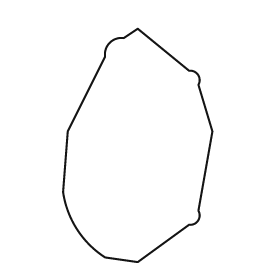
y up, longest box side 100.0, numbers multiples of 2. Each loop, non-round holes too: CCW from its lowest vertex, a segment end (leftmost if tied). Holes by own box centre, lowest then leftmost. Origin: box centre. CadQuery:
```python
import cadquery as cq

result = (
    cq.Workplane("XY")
    .moveTo(0.0, -50.0)
    .lineTo(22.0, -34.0)
    .threePointArc((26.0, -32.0), (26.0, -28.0))
    .lineTo(32.0, 6.0)
    .lineTo(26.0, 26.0)
    .threePointArc((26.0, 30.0), (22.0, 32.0))
    .lineTo(0.0, 50.0)
    .lineTo(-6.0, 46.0)
    .threePointArc((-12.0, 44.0), (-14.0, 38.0))
    .lineTo(-30.0, 6.0)
    .lineTo(-32.0, -20.0)
    .threePointArc((-26.0, -36.0), (-14.0, -48.0))
    .close()
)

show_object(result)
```